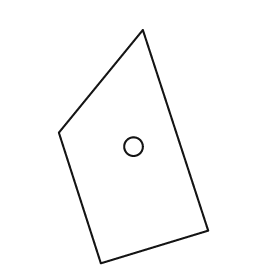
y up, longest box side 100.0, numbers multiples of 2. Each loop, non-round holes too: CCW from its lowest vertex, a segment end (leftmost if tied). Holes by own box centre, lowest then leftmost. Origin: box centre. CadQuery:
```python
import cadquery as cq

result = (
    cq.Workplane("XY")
    .moveTo(-14.0, -50.0)
    .lineTo(32.0, -36.0)
    .lineTo(4.0, 50.0)
    .lineTo(-32.0, 6.0)
    .close()
    .moveTo(0.0, 0.0)
    .circle(4.0)
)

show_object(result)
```